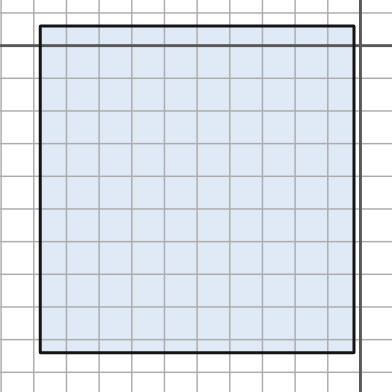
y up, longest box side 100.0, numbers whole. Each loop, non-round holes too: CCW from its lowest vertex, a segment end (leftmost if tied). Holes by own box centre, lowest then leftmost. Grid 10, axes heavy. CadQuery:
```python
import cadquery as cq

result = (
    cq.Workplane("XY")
    .moveTo(-98.0, -94.0)
    .lineTo(-2.0, -94.0)
    .lineTo(-2.0, 6.0)
    .lineTo(-98.0, 6.0)
    .close()
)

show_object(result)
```